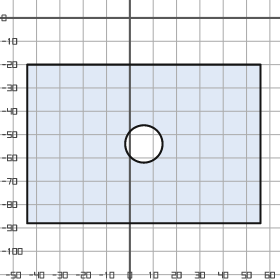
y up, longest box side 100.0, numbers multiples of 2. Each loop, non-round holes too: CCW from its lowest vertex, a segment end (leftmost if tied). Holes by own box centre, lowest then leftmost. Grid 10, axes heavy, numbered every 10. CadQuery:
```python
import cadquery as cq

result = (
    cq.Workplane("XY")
    .moveTo(-44.0, -88.0)
    .lineTo(56.0, -88.0)
    .lineTo(56.0, -20.0)
    .lineTo(-44.0, -20.0)
    .close()
    .moveTo(6.0, -54.0)
    .circle(8.0)
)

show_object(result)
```